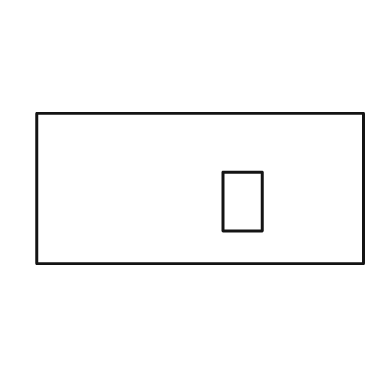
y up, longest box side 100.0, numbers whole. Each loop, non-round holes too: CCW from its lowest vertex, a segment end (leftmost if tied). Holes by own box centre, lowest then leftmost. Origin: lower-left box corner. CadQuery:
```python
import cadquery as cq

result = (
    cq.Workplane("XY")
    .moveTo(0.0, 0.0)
    .lineTo(100.0, 0.0)
    .lineTo(100.0, 46.0)
    .lineTo(0.0, 46.0)
    .close()
    .moveTo(57.0, 10.0)
    .lineTo(69.0, 10.0)
    .lineTo(69.0, 28.0)
    .lineTo(57.0, 28.0)
    .close()
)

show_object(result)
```